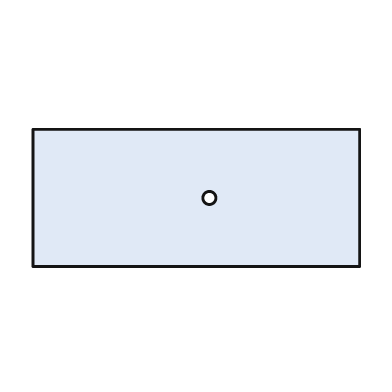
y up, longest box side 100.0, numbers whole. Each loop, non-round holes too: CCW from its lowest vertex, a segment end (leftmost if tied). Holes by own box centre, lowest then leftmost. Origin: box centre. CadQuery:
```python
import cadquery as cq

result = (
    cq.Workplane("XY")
    .moveTo(-50.0, -21.0)
    .lineTo(50.0, -21.0)
    .lineTo(50.0, 21.0)
    .lineTo(-50.0, 21.0)
    .close()
    .moveTo(4.0, 0.0)
    .circle(2.0)
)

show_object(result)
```